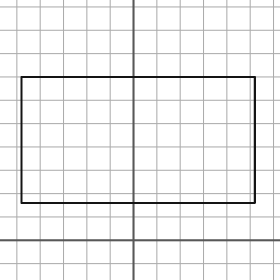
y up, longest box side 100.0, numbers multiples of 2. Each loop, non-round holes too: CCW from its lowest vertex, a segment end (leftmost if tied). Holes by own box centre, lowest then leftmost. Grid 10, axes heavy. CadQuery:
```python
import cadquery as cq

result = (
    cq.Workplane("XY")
    .moveTo(-48.0, 16.0)
    .lineTo(52.0, 16.0)
    .lineTo(52.0, 70.0)
    .lineTo(-48.0, 70.0)
    .close()
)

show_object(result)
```